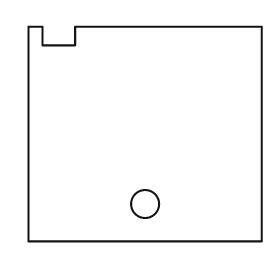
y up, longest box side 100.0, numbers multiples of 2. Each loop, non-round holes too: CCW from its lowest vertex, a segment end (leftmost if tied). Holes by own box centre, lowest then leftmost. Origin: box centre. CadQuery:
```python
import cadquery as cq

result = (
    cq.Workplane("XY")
    .moveTo(-50.0, -46.0)
    .lineTo(50.0, -46.0)
    .lineTo(50.0, 46.0)
    .lineTo(-30.0, 46.0)
    .lineTo(-30.0, 38.0)
    .lineTo(-44.0, 38.0)
    .lineTo(-44.0, 46.0)
    .lineTo(-50.0, 46.0)
    .close()
    .moveTo(0.0, -30.0)
    .circle(6.0)
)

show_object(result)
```